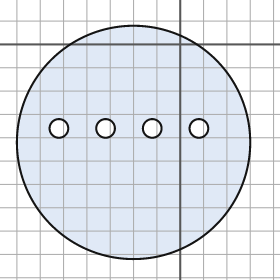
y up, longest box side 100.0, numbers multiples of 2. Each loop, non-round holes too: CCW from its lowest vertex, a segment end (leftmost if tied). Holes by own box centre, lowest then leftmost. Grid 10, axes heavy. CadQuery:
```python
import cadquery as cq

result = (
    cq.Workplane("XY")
    .moveTo(-20.0, -42.0)
    .circle(50.0)
    .moveTo(-52.0, -36.0)
    .circle(4.0)
    .moveTo(-32.0, -36.0)
    .circle(4.0)
    .moveTo(-12.0, -36.0)
    .circle(4.0)
    .moveTo(8.0, -36.0)
    .circle(4.0)
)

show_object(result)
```